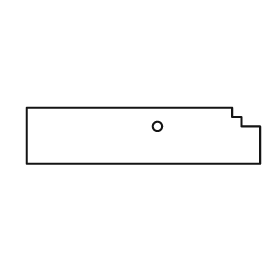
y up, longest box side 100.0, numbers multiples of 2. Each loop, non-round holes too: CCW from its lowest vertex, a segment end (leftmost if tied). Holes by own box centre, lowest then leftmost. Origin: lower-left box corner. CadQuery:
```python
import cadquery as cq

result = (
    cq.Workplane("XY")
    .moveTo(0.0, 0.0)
    .lineTo(100.0, 0.0)
    .lineTo(100.0, 16.0)
    .lineTo(92.0, 16.0)
    .lineTo(92.0, 20.0)
    .lineTo(88.0, 20.0)
    .lineTo(88.0, 24.0)
    .lineTo(0.0, 24.0)
    .close()
    .moveTo(56.0, 16.0)
    .circle(2.0)
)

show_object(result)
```